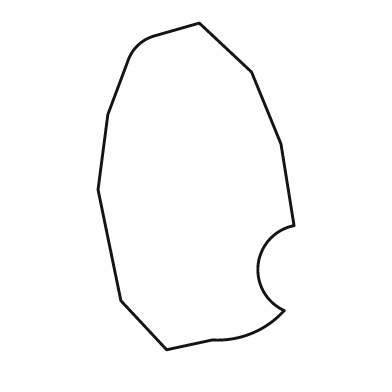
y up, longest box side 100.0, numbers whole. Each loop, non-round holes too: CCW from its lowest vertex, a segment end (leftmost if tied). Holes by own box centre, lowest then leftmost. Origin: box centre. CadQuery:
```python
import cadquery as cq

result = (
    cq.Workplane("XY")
    .moveTo(-9.0, -50.0)
    .lineTo(5.0, -47.0)
    .threePointArc((17.0, -45.0), (27.0, -38.0))
    .threePointArc((19.0, -24.0), (30.0, -12.0))
    .lineTo(26.0, 13.0)
    .lineTo(17.0, 35.0)
    .lineTo(1.0, 50.0)
    .lineTo(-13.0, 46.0)
    .threePointArc((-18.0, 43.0), (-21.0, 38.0))
    .lineTo(-27.0, 22.0)
    .lineTo(-30.0, -1.0)
    .lineTo(-23.0, -35.0)
    .close()
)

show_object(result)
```